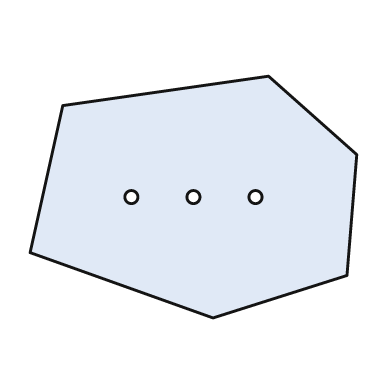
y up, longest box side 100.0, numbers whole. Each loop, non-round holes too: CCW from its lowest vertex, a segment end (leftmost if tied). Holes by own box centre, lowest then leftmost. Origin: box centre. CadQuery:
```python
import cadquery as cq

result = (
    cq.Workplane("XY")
    .moveTo(6.0, -37.0)
    .lineTo(47.0, -24.0)
    .lineTo(50.0, 13.0)
    .lineTo(23.0, 37.0)
    .lineTo(-40.0, 28.0)
    .lineTo(-50.0, -17.0)
    .close()
    .moveTo(-19.0, 0.0)
    .circle(2.0)
    .moveTo(0.0, 0.0)
    .circle(2.0)
    .moveTo(19.0, 0.0)
    .circle(2.0)
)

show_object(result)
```